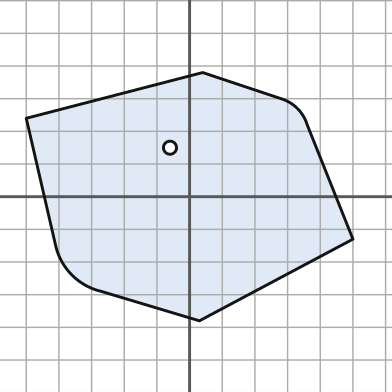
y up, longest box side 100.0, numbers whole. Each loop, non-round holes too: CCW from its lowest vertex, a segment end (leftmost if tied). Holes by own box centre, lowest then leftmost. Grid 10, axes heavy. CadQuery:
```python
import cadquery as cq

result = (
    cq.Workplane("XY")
    .moveTo(3.0, -38.0)
    .lineTo(50.0, -13.0)
    .lineTo(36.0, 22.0)
    .threePointArc((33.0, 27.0), (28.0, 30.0))
    .lineTo(4.0, 38.0)
    .lineTo(-50.0, 24.0)
    .lineTo(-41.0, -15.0)
    .threePointArc((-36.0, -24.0), (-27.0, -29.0))
    .close()
    .moveTo(-6.0, 15.0)
    .circle(2.0)
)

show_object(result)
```